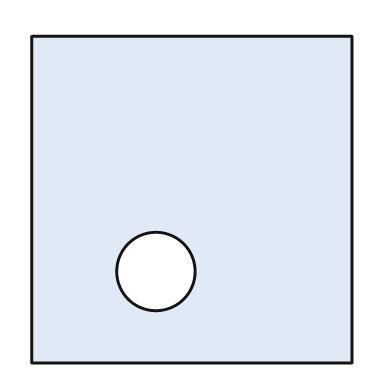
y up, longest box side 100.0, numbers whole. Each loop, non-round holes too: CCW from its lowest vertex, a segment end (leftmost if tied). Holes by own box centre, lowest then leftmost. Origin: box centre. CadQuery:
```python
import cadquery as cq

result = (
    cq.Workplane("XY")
    .moveTo(-49.0, -50.0)
    .lineTo(49.0, -50.0)
    .lineTo(49.0, 50.0)
    .lineTo(-49.0, 50.0)
    .close()
    .moveTo(-11.0, -22.0)
    .circle(12.0)
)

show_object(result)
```